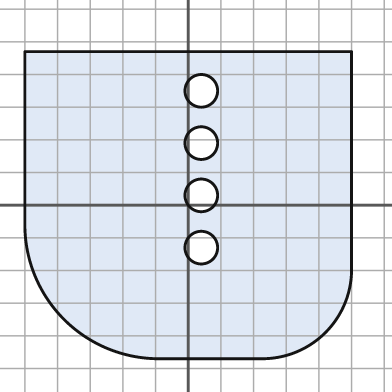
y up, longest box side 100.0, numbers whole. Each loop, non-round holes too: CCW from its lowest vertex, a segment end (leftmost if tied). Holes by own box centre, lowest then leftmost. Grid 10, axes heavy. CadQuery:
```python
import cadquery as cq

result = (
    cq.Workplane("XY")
    .moveTo(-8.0, -47.0)
    .lineTo(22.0, -47.0)
    .threePointArc((42.0, -39.0), (50.0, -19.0))
    .lineTo(50.0, 47.0)
    .lineTo(-50.0, 47.0)
    .lineTo(-50.0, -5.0)
    .threePointArc((-38.0, -35.0), (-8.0, -47.0))
    .close()
    .moveTo(4.0, -13.0)
    .circle(5.0)
    .moveTo(4.0, 3.0)
    .circle(5.0)
    .moveTo(4.0, 19.0)
    .circle(5.0)
    .moveTo(4.0, 35.0)
    .circle(5.0)
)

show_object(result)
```